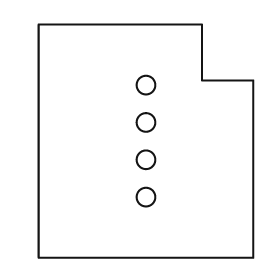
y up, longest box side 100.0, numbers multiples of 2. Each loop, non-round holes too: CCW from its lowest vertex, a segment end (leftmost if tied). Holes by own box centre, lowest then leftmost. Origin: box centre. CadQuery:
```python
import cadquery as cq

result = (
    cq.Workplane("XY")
    .moveTo(-46.0, -50.0)
    .lineTo(46.0, -50.0)
    .lineTo(46.0, 26.0)
    .lineTo(24.0, 26.0)
    .lineTo(24.0, 50.0)
    .lineTo(-46.0, 50.0)
    .close()
    .moveTo(0.0, -24.0)
    .circle(4.0)
    .moveTo(0.0, -8.0)
    .circle(4.0)
    .moveTo(0.0, 8.0)
    .circle(4.0)
    .moveTo(0.0, 24.0)
    .circle(4.0)
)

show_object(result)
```